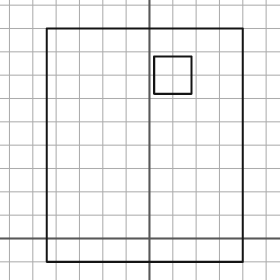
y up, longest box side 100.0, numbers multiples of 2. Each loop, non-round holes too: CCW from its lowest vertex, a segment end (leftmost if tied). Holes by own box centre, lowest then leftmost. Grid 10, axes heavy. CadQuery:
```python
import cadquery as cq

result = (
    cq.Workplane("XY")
    .moveTo(-44.0, -10.0)
    .lineTo(40.0, -10.0)
    .lineTo(40.0, 90.0)
    .lineTo(-44.0, 90.0)
    .close()
    .moveTo(2.0, 62.0)
    .lineTo(18.0, 62.0)
    .lineTo(18.0, 78.0)
    .lineTo(2.0, 78.0)
    .close()
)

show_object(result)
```